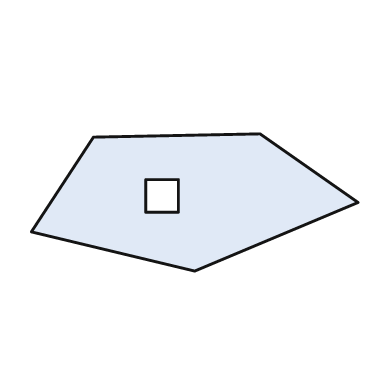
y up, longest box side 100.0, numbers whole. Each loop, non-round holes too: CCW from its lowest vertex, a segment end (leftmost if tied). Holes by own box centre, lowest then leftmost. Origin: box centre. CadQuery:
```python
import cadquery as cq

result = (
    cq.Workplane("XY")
    .moveTo(0.0, -21.0)
    .lineTo(50.0, 0.0)
    .lineTo(20.0, 21.0)
    .lineTo(-31.0, 20.0)
    .lineTo(-50.0, -9.0)
    .close()
    .moveTo(-15.0, -3.0)
    .lineTo(-5.0, -3.0)
    .lineTo(-5.0, 7.0)
    .lineTo(-15.0, 7.0)
    .close()
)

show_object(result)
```